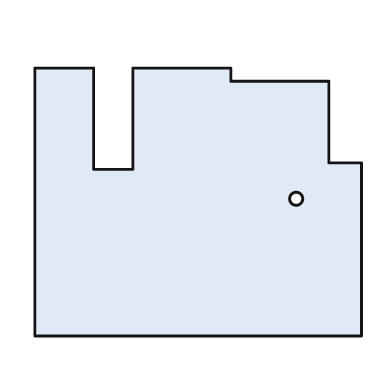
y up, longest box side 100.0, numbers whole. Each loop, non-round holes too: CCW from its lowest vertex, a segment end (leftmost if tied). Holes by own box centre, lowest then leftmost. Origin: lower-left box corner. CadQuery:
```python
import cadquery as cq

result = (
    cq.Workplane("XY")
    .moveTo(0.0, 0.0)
    .lineTo(100.0, 0.0)
    .lineTo(100.0, 53.0)
    .lineTo(90.0, 53.0)
    .lineTo(90.0, 78.0)
    .lineTo(60.0, 78.0)
    .lineTo(60.0, 82.0)
    .lineTo(30.0, 82.0)
    .lineTo(30.0, 51.0)
    .lineTo(18.0, 51.0)
    .lineTo(18.0, 82.0)
    .lineTo(0.0, 82.0)
    .close()
    .moveTo(80.0, 42.0)
    .circle(2.0)
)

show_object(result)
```